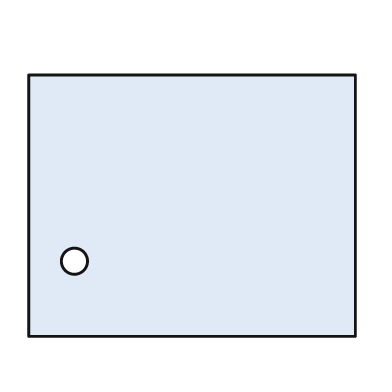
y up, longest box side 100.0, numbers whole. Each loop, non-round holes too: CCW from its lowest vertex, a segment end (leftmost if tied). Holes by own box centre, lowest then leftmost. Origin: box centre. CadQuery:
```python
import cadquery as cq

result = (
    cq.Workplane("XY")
    .moveTo(-50.0, -40.0)
    .lineTo(50.0, -40.0)
    .lineTo(50.0, 40.0)
    .lineTo(-50.0, 40.0)
    .close()
    .moveTo(-36.0, -17.0)
    .circle(4.0)
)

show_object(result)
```